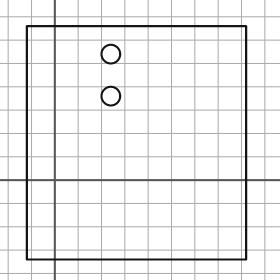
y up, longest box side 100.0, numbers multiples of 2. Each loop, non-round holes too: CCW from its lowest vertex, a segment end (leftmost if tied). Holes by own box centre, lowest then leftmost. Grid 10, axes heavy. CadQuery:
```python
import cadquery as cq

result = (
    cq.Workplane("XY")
    .moveTo(-12.0, -34.0)
    .lineTo(82.0, -34.0)
    .lineTo(82.0, 66.0)
    .lineTo(-12.0, 66.0)
    .close()
    .moveTo(24.0, 36.0)
    .circle(4.0)
    .moveTo(24.0, 54.0)
    .circle(4.0)
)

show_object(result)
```